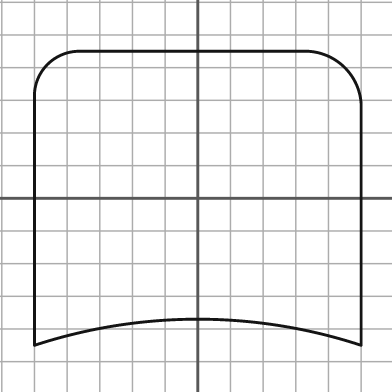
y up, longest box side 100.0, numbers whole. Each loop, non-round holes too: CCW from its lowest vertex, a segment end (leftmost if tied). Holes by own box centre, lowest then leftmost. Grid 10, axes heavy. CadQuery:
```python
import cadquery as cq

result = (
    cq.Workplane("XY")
    .moveTo(-50.0, -45.0)
    .threePointArc((0.0, -37.0), (50.0, -45.0))
    .lineTo(50.0, 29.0)
    .threePointArc((45.0, 40.0), (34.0, 45.0))
    .lineTo(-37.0, 45.0)
    .threePointArc((-46.0, 41.0), (-50.0, 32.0))
    .close()
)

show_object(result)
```